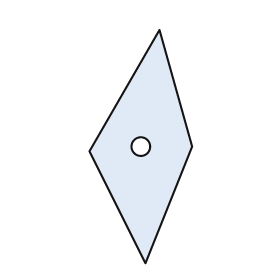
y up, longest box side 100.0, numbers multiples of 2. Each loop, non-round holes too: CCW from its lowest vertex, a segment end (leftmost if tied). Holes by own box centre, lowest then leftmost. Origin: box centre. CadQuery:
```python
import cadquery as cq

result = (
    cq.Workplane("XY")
    .moveTo(2.0, -50.0)
    .lineTo(22.0, 0.0)
    .lineTo(8.0, 50.0)
    .lineTo(-22.0, -2.0)
    .close()
    .moveTo(0.0, 0.0)
    .circle(4.0)
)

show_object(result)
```